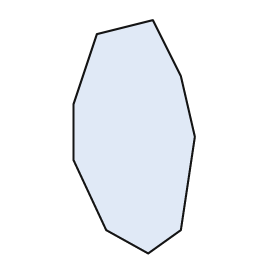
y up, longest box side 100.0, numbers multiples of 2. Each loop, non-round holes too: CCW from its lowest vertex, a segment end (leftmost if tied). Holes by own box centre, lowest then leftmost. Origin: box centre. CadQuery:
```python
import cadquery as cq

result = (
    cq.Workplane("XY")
    .moveTo(6.0, -50.0)
    .lineTo(20.0, -40.0)
    .lineTo(26.0, 0.0)
    .lineTo(20.0, 26.0)
    .lineTo(8.0, 50.0)
    .lineTo(-16.0, 44.0)
    .lineTo(-26.0, 14.0)
    .lineTo(-26.0, -10.0)
    .lineTo(-12.0, -40.0)
    .close()
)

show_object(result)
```